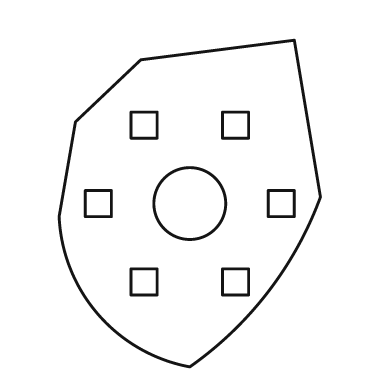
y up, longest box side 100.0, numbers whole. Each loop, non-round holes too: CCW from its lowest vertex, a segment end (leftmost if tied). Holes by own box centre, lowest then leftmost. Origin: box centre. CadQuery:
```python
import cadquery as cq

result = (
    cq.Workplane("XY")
    .moveTo(0.0, -50.0)
    .threePointArc((24.0, -27.0), (40.0, 2.0))
    .lineTo(32.0, 50.0)
    .lineTo(-15.0, 44.0)
    .lineTo(-35.0, 25.0)
    .lineTo(-40.0, -4.0)
    .threePointArc((-28.0, -34.0), (0.0, -50.0))
    .close()
    .moveTo(-18.0, -28.0)
    .lineTo(-10.0, -28.0)
    .lineTo(-10.0, -20.0)
    .lineTo(-18.0, -20.0)
    .close()
    .moveTo(10.0, -28.0)
    .lineTo(18.0, -28.0)
    .lineTo(18.0, -20.0)
    .lineTo(10.0, -20.0)
    .close()
    .moveTo(-32.0, -4.0)
    .lineTo(-24.0, -4.0)
    .lineTo(-24.0, 4.0)
    .lineTo(-32.0, 4.0)
    .close()
    .moveTo(0.0, 0.0)
    .circle(11.0)
    .moveTo(24.0, -4.0)
    .lineTo(32.0, -4.0)
    .lineTo(32.0, 4.0)
    .lineTo(24.0, 4.0)
    .close()
    .moveTo(-18.0, 20.0)
    .lineTo(-10.0, 20.0)
    .lineTo(-10.0, 28.0)
    .lineTo(-18.0, 28.0)
    .close()
    .moveTo(10.0, 20.0)
    .lineTo(18.0, 20.0)
    .lineTo(18.0, 28.0)
    .lineTo(10.0, 28.0)
    .close()
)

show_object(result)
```